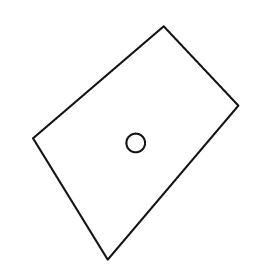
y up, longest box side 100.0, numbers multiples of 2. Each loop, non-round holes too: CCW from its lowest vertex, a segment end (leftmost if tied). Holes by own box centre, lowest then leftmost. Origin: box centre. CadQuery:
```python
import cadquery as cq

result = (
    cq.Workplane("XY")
    .moveTo(-12.0, -50.0)
    .lineTo(44.0, 16.0)
    .lineTo(12.0, 50.0)
    .lineTo(-44.0, 2.0)
    .close()
    .moveTo(0.0, 0.0)
    .circle(4.0)
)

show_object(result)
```